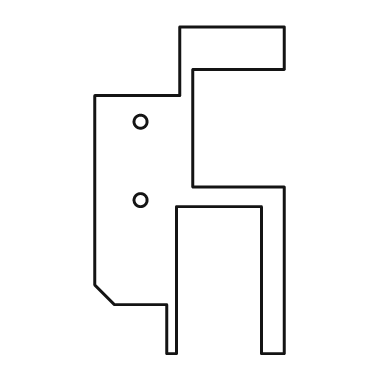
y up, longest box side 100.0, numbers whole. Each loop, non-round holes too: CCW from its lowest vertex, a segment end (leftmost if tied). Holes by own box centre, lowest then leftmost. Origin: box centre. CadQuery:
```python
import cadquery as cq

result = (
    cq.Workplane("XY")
    .moveTo(-7.0, -50.0)
    .lineTo(-4.0, -50.0)
    .lineTo(-4.0, -5.0)
    .lineTo(22.0, -5.0)
    .lineTo(22.0, -50.0)
    .lineTo(29.0, -50.0)
    .lineTo(29.0, 1.0)
    .lineTo(1.0, 1.0)
    .lineTo(1.0, 37.0)
    .lineTo(29.0, 37.0)
    .lineTo(29.0, 50.0)
    .lineTo(-3.0, 50.0)
    .lineTo(-3.0, 29.0)
    .lineTo(-29.0, 29.0)
    .lineTo(-29.0, -29.0)
    .lineTo(-23.0, -35.0)
    .lineTo(-7.0, -35.0)
    .close()
    .moveTo(-15.0, -3.0)
    .circle(2.0)
    .moveTo(-15.0, 21.0)
    .circle(2.0)
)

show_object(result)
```